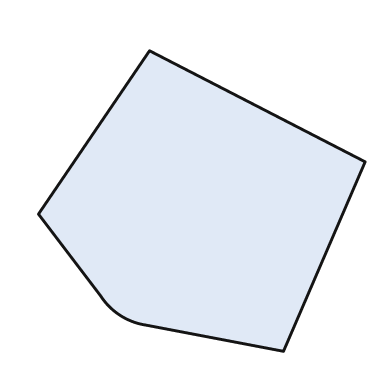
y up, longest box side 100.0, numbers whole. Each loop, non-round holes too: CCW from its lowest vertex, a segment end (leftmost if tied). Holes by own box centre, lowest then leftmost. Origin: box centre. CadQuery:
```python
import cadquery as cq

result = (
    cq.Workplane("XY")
    .moveTo(25.0, -46.0)
    .lineTo(50.0, 12.0)
    .lineTo(-16.0, 46.0)
    .lineTo(-50.0, -4.0)
    .lineTo(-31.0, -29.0)
    .threePointArc((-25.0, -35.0), (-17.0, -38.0))
    .close()
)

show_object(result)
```